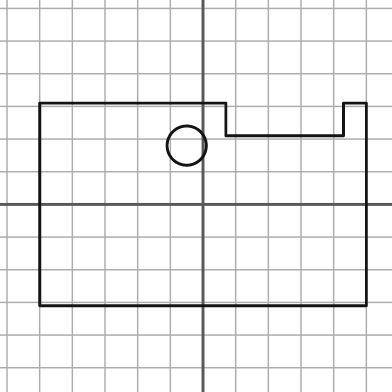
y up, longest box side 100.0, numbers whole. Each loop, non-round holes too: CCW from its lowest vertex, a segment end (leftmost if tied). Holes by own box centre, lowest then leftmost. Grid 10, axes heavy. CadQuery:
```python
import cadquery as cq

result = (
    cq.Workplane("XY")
    .moveTo(-50.0, -31.0)
    .lineTo(50.0, -31.0)
    .lineTo(50.0, 31.0)
    .lineTo(43.0, 31.0)
    .lineTo(43.0, 21.0)
    .lineTo(7.0, 21.0)
    .lineTo(7.0, 31.0)
    .lineTo(-50.0, 31.0)
    .close()
    .moveTo(-5.0, 18.0)
    .circle(6.0)
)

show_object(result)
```